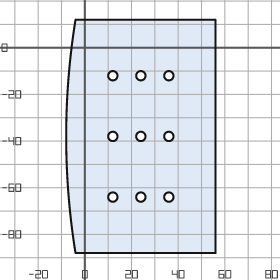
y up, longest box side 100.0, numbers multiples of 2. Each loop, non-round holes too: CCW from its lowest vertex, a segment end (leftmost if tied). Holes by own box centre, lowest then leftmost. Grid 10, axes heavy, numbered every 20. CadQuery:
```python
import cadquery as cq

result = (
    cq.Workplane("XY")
    .moveTo(-4.0, -88.0)
    .lineTo(56.0, -88.0)
    .lineTo(56.0, 12.0)
    .lineTo(-4.0, 12.0)
    .threePointArc((-8.0, -38.0), (-4.0, -88.0))
    .close()
    .moveTo(12.0, -64.0)
    .circle(2.0)
    .moveTo(24.0, -64.0)
    .circle(2.0)
    .moveTo(36.0, -64.0)
    .circle(2.0)
    .moveTo(12.0, -38.0)
    .circle(2.0)
    .moveTo(24.0, -38.0)
    .circle(2.0)
    .moveTo(36.0, -38.0)
    .circle(2.0)
    .moveTo(12.0, -12.0)
    .circle(2.0)
    .moveTo(24.0, -12.0)
    .circle(2.0)
    .moveTo(36.0, -12.0)
    .circle(2.0)
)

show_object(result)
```